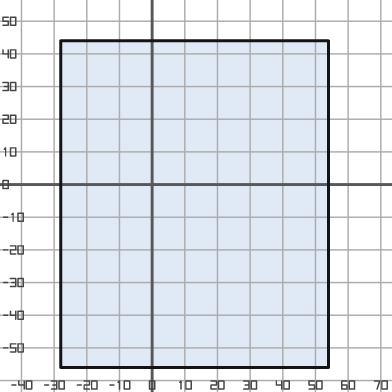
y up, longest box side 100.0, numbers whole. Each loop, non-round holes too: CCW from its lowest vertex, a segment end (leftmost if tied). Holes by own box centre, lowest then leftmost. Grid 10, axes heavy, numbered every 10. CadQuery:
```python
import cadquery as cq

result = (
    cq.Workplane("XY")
    .moveTo(-28.0, -56.0)
    .lineTo(54.0, -56.0)
    .lineTo(54.0, 44.0)
    .lineTo(-28.0, 44.0)
    .close()
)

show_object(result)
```